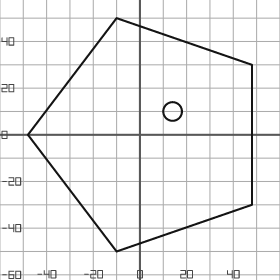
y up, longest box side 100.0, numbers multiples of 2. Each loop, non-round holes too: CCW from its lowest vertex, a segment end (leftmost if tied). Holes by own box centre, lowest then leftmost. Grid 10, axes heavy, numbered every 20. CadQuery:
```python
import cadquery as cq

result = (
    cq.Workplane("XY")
    .moveTo(-10.0, -50.0)
    .lineTo(48.0, -30.0)
    .lineTo(48.0, 30.0)
    .lineTo(-10.0, 50.0)
    .lineTo(-48.0, 0.0)
    .close()
    .moveTo(14.0, 10.0)
    .circle(4.0)
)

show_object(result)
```